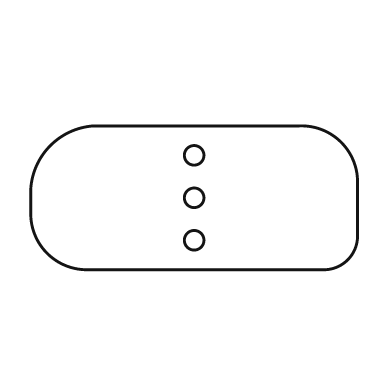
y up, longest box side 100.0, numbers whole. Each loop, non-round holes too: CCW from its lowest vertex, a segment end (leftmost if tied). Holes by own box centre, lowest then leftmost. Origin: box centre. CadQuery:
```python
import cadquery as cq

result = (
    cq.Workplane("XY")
    .moveTo(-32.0, -22.0)
    .lineTo(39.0, -22.0)
    .threePointArc((47.0, -19.0), (50.0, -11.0))
    .lineTo(50.0, 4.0)
    .threePointArc((45.0, 17.0), (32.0, 22.0))
    .lineTo(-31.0, 22.0)
    .threePointArc((-44.0, 16.0), (-50.0, 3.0))
    .lineTo(-50.0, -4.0)
    .threePointArc((-45.0, -17.0), (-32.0, -22.0))
    .close()
    .moveTo(0.0, -13.0)
    .circle(3.0)
    .moveTo(0.0, 0.0)
    .circle(3.0)
    .moveTo(0.0, 13.0)
    .circle(3.0)
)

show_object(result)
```